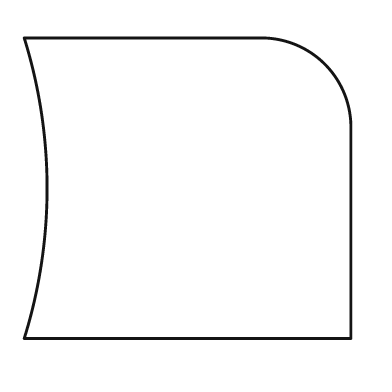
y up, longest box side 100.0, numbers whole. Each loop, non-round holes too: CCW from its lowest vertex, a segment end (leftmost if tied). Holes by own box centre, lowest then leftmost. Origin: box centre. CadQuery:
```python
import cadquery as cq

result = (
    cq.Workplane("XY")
    .moveTo(-50.0, -46.0)
    .lineTo(50.0, -46.0)
    .lineTo(50.0, 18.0)
    .threePointArc((42.0, 38.0), (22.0, 46.0))
    .lineTo(-50.0, 46.0)
    .threePointArc((-43.0, 0.0), (-50.0, -46.0))
    .close()
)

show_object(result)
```